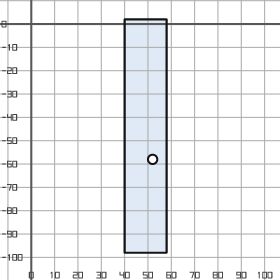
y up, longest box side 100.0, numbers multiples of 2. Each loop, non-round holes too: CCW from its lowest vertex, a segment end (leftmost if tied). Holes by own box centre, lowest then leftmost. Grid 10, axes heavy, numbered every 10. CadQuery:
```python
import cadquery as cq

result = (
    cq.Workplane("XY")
    .moveTo(40.0, -98.0)
    .lineTo(58.0, -98.0)
    .lineTo(58.0, 2.0)
    .lineTo(40.0, 2.0)
    .close()
    .moveTo(52.0, -58.0)
    .circle(2.0)
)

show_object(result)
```